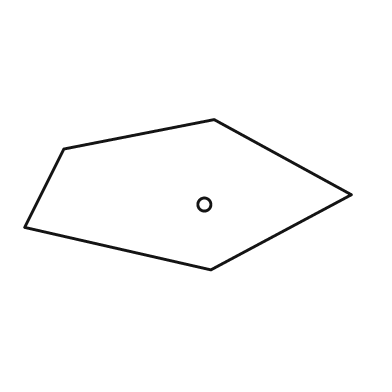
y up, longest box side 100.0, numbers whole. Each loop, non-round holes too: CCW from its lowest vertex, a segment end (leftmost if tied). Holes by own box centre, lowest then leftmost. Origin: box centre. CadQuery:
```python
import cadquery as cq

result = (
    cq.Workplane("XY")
    .moveTo(7.0, -23.0)
    .lineTo(50.0, 0.0)
    .lineTo(8.0, 23.0)
    .lineTo(-38.0, 14.0)
    .lineTo(-50.0, -10.0)
    .close()
    .moveTo(5.0, -3.0)
    .circle(2.0)
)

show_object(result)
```